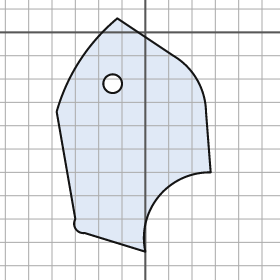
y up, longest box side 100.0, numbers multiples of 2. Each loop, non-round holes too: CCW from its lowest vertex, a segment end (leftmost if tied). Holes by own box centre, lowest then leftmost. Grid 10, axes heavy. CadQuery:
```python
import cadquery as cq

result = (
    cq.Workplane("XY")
    .moveTo(0.0, -94.0)
    .threePointArc((6.0, -70.0), (28.0, -60.0))
    .lineTo(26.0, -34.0)
    .threePointArc((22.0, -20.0), (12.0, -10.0))
    .lineTo(-12.0, 6.0)
    .threePointArc((-28.0, -12.0), (-38.0, -34.0))
    .lineTo(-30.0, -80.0)
    .threePointArc((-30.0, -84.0), (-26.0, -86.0))
    .close()
    .moveTo(-14.0, -22.0)
    .circle(4.0)
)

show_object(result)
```